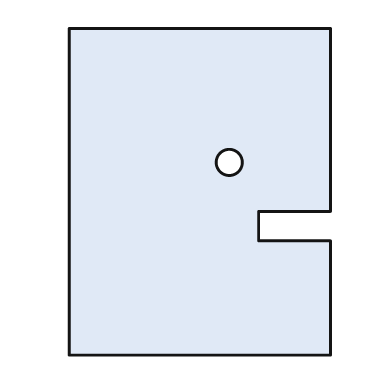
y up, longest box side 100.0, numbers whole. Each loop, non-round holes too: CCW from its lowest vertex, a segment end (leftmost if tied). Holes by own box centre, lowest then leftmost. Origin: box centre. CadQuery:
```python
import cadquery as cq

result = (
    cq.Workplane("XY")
    .moveTo(-40.0, -50.0)
    .lineTo(40.0, -50.0)
    .lineTo(40.0, -15.0)
    .lineTo(18.0, -15.0)
    .lineTo(18.0, -6.0)
    .lineTo(40.0, -6.0)
    .lineTo(40.0, 50.0)
    .lineTo(-40.0, 50.0)
    .close()
    .moveTo(9.0, 9.0)
    .circle(4.0)
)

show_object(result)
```